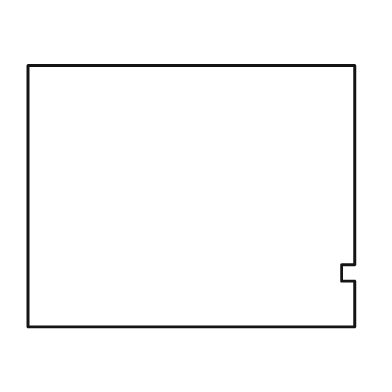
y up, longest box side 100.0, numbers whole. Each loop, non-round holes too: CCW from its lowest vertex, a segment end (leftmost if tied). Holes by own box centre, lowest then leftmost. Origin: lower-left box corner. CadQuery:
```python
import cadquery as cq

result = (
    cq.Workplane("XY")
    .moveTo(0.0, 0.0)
    .lineTo(100.0, 0.0)
    .lineTo(100.0, 14.0)
    .lineTo(96.0, 14.0)
    .lineTo(96.0, 19.0)
    .lineTo(100.0, 19.0)
    .lineTo(100.0, 80.0)
    .lineTo(0.0, 80.0)
    .close()
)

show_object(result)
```